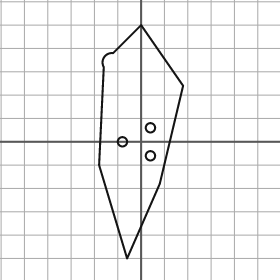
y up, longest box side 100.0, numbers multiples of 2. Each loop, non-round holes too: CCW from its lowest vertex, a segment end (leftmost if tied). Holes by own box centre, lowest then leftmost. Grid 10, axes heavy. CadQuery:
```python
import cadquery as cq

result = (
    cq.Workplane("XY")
    .moveTo(-6.0, -50.0)
    .lineTo(8.0, -18.0)
    .lineTo(18.0, 24.0)
    .lineTo(0.0, 50.0)
    .lineTo(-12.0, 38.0)
    .threePointArc((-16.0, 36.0), (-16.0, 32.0))
    .lineTo(-18.0, -10.0)
    .close()
    .moveTo(4.0, -6.0)
    .circle(2.0)
    .moveTo(-8.0, 0.0)
    .circle(2.0)
    .moveTo(4.0, 6.0)
    .circle(2.0)
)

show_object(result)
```